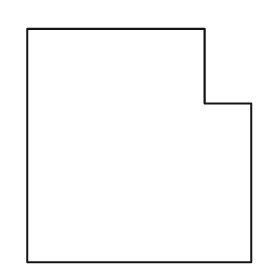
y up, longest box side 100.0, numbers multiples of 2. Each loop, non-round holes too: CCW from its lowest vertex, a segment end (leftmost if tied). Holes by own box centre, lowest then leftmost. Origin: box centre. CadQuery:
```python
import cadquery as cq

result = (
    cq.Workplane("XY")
    .moveTo(-48.0, -50.0)
    .lineTo(48.0, -50.0)
    .lineTo(48.0, 18.0)
    .lineTo(28.0, 18.0)
    .lineTo(28.0, 50.0)
    .lineTo(-48.0, 50.0)
    .close()
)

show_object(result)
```